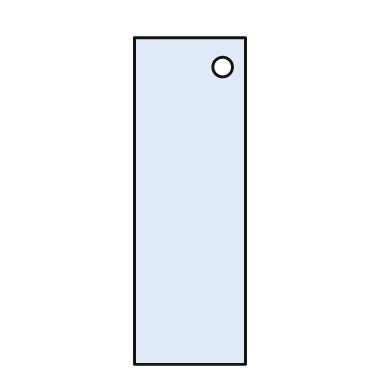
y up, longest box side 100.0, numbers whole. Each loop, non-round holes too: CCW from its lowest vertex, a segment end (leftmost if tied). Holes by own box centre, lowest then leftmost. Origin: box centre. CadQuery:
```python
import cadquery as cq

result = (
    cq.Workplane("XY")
    .moveTo(-17.0, -50.0)
    .lineTo(17.0, -50.0)
    .lineTo(17.0, 50.0)
    .lineTo(-17.0, 50.0)
    .close()
    .moveTo(10.0, 41.0)
    .circle(3.0)
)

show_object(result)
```